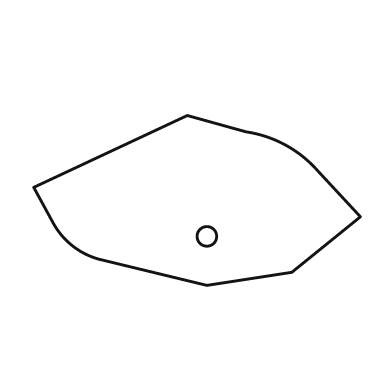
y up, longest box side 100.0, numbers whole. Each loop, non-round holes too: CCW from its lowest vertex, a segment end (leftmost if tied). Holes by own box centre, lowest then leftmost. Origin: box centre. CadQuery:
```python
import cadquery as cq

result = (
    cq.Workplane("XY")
    .moveTo(3.0, -26.0)
    .lineTo(29.0, -22.0)
    .lineTo(50.0, -5.0)
    .lineTo(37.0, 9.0)
    .threePointArc((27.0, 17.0), (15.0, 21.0))
    .lineTo(-3.0, 26.0)
    .lineTo(-50.0, 4.0)
    .lineTo(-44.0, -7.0)
    .threePointArc((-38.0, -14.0), (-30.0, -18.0))
    .close()
    .moveTo(3.0, -11.0)
    .circle(3.0)
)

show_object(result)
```